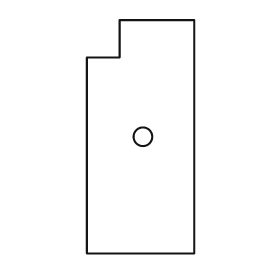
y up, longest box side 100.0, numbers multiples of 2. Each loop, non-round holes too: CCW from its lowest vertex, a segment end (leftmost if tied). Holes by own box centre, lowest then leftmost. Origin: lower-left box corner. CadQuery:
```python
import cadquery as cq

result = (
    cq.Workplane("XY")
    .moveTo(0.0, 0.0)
    .lineTo(46.0, 0.0)
    .lineTo(46.0, 100.0)
    .lineTo(14.0, 100.0)
    .lineTo(14.0, 84.0)
    .lineTo(0.0, 84.0)
    .close()
    .moveTo(24.0, 50.0)
    .circle(4.0)
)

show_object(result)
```